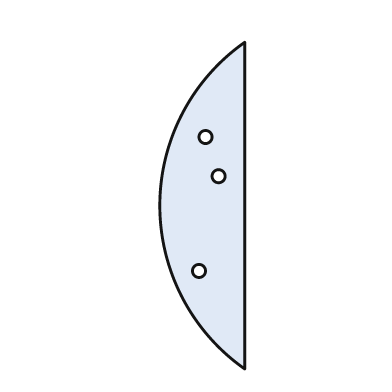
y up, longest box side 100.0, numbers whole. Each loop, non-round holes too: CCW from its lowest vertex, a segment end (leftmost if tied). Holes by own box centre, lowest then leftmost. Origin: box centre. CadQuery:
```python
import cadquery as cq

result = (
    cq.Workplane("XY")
    .moveTo(13.0, -50.0)
    .lineTo(13.0, 50.0)
    .threePointArc((-13.0, 0.0), (13.0, -50.0))
    .close()
    .moveTo(-1.0, -20.0)
    .circle(2.0)
    .moveTo(5.0, 9.0)
    .circle(2.0)
    .moveTo(1.0, 21.0)
    .circle(2.0)
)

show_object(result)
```